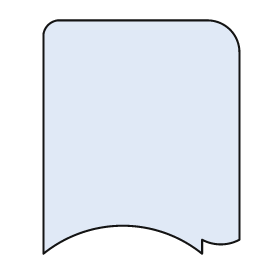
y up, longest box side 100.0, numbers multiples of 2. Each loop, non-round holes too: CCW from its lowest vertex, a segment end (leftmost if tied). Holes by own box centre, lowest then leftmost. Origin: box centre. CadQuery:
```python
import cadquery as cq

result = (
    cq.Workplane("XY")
    .moveTo(-42.0, -50.0)
    .threePointArc((-8.0, -38.0), (26.0, -50.0))
    .lineTo(26.0, -44.0)
    .threePointArc((34.0, -46.0), (42.0, -44.0))
    .lineTo(42.0, 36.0)
    .threePointArc((38.0, 46.0), (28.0, 50.0))
    .lineTo(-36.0, 50.0)
    .threePointArc((-40.0, 48.0), (-42.0, 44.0))
    .close()
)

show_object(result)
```